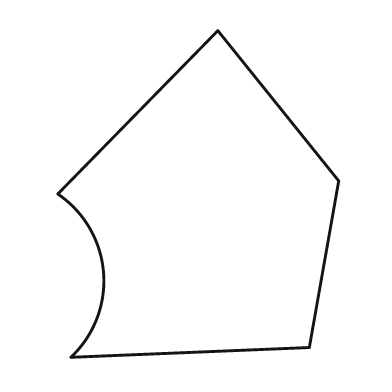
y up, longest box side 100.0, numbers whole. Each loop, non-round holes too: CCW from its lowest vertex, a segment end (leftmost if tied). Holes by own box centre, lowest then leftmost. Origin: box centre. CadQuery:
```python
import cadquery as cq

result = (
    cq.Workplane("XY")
    .moveTo(-39.0, -50.0)
    .lineTo(34.0, -47.0)
    .lineTo(43.0, 4.0)
    .lineTo(6.0, 50.0)
    .lineTo(-43.0, 0.0)
    .threePointArc((-29.0, -24.0), (-39.0, -50.0))
    .close()
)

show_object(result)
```